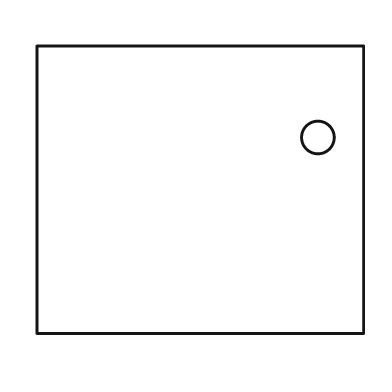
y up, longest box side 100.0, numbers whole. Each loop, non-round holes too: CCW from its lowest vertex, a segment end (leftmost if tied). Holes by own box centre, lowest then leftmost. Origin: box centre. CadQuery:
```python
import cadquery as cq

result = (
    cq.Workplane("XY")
    .moveTo(-50.0, -44.0)
    .lineTo(50.0, -44.0)
    .lineTo(50.0, 44.0)
    .lineTo(-50.0, 44.0)
    .close()
    .moveTo(36.0, 16.0)
    .circle(5.0)
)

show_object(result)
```